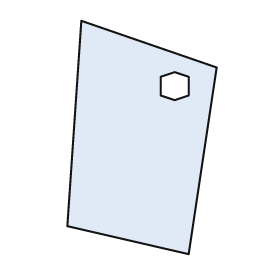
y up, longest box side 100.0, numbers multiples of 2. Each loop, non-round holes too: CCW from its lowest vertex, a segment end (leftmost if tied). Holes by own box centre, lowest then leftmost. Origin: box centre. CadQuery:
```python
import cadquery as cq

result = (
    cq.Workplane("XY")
    .moveTo(20.0, -50.0)
    .lineTo(32.0, 30.0)
    .lineTo(-26.0, 50.0)
    .lineTo(-32.0, -38.0)
    .close()
    .moveTo(14.0, 16.0)
    .lineTo(20.0, 18.0)
    .lineTo(20.0, 26.0)
    .lineTo(14.0, 28.0)
    .lineTo(8.0, 26.0)
    .lineTo(8.0, 18.0)
    .close()
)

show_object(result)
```